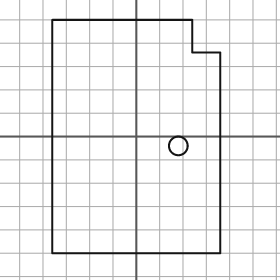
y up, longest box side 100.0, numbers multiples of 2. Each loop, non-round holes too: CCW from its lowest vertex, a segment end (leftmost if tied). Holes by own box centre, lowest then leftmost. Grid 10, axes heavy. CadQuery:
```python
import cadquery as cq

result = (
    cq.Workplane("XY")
    .moveTo(-36.0, -50.0)
    .lineTo(36.0, -50.0)
    .lineTo(36.0, 36.0)
    .lineTo(24.0, 36.0)
    .lineTo(24.0, 50.0)
    .lineTo(-36.0, 50.0)
    .close()
    .moveTo(18.0, -4.0)
    .circle(4.0)
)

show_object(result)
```